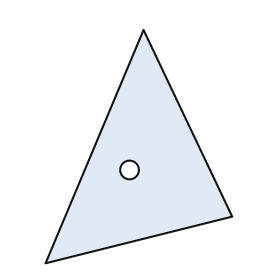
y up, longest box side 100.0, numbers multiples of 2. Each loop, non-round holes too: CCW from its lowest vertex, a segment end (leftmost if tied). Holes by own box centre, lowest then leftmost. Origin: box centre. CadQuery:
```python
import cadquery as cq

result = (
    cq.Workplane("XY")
    .moveTo(-40.0, -50.0)
    .lineTo(40.0, -30.0)
    .lineTo(2.0, 50.0)
    .close()
    .moveTo(-4.0, -10.0)
    .circle(4.0)
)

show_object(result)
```